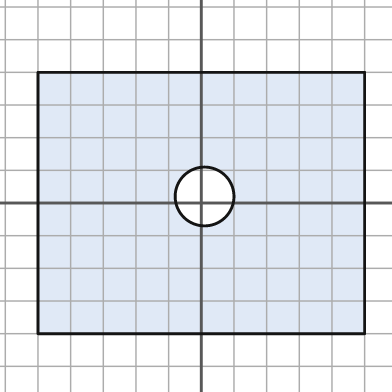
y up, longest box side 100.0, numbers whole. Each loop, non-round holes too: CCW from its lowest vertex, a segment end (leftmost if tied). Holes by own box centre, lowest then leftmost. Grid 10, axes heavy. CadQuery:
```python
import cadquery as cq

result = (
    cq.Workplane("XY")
    .moveTo(-50.0, -40.0)
    .lineTo(50.0, -40.0)
    .lineTo(50.0, 40.0)
    .lineTo(-50.0, 40.0)
    .close()
    .moveTo(1.0, 2.0)
    .circle(9.0)
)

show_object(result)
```